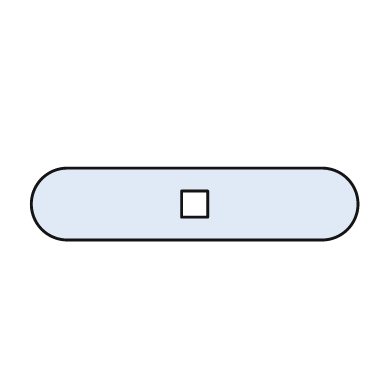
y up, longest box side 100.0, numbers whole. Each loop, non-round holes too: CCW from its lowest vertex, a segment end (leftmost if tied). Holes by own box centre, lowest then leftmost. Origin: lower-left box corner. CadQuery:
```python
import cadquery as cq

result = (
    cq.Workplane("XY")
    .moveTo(11.0, 0.0)
    .lineTo(89.0, 0.0)
    .threePointArc((100.0, 11.0), (89.0, 22.0))
    .lineTo(11.0, 22.0)
    .threePointArc((0.0, 11.0), (11.0, 0.0))
    .close()
    .moveTo(46.0, 7.0)
    .lineTo(54.0, 7.0)
    .lineTo(54.0, 15.0)
    .lineTo(46.0, 15.0)
    .close()
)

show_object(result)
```